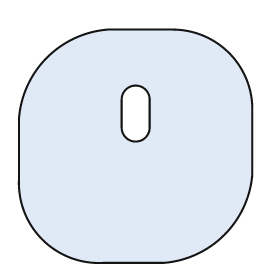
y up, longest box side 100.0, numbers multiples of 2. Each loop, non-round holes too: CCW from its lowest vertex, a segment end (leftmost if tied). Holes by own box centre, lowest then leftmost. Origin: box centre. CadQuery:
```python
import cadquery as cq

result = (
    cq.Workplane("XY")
    .moveTo(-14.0, -50.0)
    .lineTo(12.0, -50.0)
    .threePointArc((38.0, -38.0), (50.0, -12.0))
    .lineTo(50.0, 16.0)
    .threePointArc((40.0, 40.0), (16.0, 50.0))
    .lineTo(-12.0, 50.0)
    .threePointArc((-38.0, 38.0), (-50.0, 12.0))
    .lineTo(-50.0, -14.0)
    .threePointArc((-40.0, -40.0), (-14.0, -50.0))
    .close()
    .moveTo(-6.0, 8.0)
    .threePointArc((0.0, 2.0), (6.0, 8.0))
    .lineTo(6.0, 20.0)
    .threePointArc((0.0, 26.0), (-6.0, 20.0))
    .close()
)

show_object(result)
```